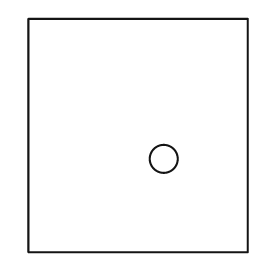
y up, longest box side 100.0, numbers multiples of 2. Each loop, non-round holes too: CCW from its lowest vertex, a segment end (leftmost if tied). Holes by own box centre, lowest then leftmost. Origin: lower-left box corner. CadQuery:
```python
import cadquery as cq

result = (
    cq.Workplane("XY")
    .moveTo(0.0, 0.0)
    .lineTo(94.0, 0.0)
    .lineTo(94.0, 100.0)
    .lineTo(0.0, 100.0)
    .close()
    .moveTo(58.0, 40.0)
    .circle(6.0)
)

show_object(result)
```